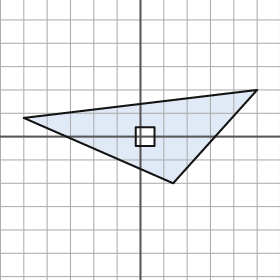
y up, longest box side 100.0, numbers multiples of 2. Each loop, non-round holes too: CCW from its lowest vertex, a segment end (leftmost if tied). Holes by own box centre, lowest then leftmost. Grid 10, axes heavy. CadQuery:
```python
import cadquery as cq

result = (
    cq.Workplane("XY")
    .moveTo(14.0, -20.0)
    .lineTo(50.0, 20.0)
    .lineTo(-50.0, 8.0)
    .close()
    .moveTo(-2.0, -4.0)
    .lineTo(6.0, -4.0)
    .lineTo(6.0, 4.0)
    .lineTo(-2.0, 4.0)
    .close()
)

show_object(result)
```